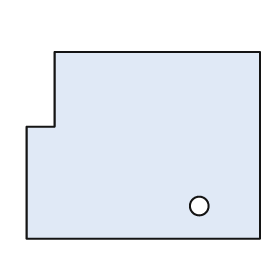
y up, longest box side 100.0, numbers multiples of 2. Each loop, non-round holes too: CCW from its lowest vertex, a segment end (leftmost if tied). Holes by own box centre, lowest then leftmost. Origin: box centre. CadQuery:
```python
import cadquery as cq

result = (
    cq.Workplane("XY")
    .moveTo(-50.0, -40.0)
    .lineTo(50.0, -40.0)
    .lineTo(50.0, 40.0)
    .lineTo(-38.0, 40.0)
    .lineTo(-38.0, 8.0)
    .lineTo(-50.0, 8.0)
    .close()
    .moveTo(24.0, -26.0)
    .circle(4.0)
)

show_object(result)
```